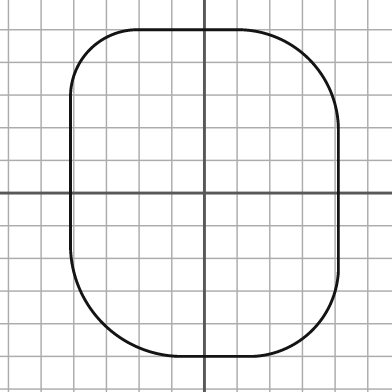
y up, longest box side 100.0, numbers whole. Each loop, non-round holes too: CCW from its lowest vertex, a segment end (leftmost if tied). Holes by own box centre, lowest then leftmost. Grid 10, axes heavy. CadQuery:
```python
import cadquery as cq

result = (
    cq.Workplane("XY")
    .moveTo(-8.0, -50.0)
    .lineTo(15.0, -50.0)
    .threePointArc((33.0, -42.0), (41.0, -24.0))
    .lineTo(41.0, 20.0)
    .threePointArc((32.0, 41.0), (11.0, 50.0))
    .lineTo(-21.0, 50.0)
    .threePointArc((-35.0, 44.0), (-41.0, 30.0))
    .lineTo(-41.0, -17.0)
    .threePointArc((-31.0, -40.0), (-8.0, -50.0))
    .close()
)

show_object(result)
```